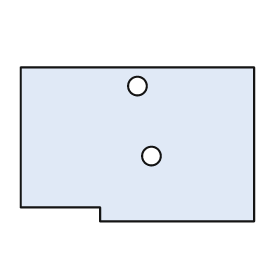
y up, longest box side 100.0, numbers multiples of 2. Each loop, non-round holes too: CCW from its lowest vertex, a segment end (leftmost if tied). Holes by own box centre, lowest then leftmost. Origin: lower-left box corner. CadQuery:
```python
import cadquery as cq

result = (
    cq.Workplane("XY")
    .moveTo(34.0, 0.0)
    .lineTo(100.0, 0.0)
    .lineTo(100.0, 66.0)
    .lineTo(0.0, 66.0)
    .lineTo(0.0, 6.0)
    .lineTo(34.0, 6.0)
    .close()
    .moveTo(56.0, 28.0)
    .circle(4.0)
    .moveTo(50.0, 58.0)
    .circle(4.0)
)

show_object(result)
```